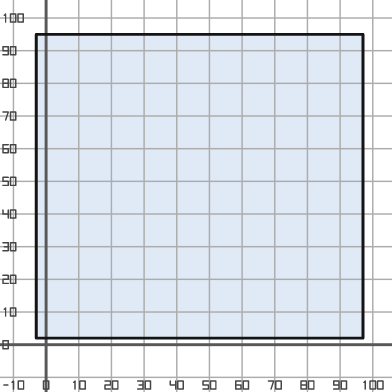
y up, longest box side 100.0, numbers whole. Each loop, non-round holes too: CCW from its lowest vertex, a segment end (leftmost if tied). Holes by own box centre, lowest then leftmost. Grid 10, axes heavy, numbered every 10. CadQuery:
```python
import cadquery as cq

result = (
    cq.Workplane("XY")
    .moveTo(-3.0, 2.0)
    .lineTo(97.0, 2.0)
    .lineTo(97.0, 95.0)
    .lineTo(-3.0, 95.0)
    .close()
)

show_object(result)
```